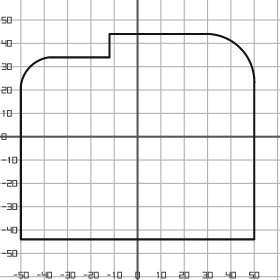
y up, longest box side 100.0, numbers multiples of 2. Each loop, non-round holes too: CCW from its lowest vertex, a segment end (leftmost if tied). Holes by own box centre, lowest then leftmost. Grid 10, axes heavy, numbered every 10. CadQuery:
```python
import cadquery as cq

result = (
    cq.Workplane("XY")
    .moveTo(-50.0, -44.0)
    .lineTo(50.0, -44.0)
    .lineTo(50.0, 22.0)
    .threePointArc((44.0, 38.0), (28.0, 44.0))
    .lineTo(-12.0, 44.0)
    .lineTo(-12.0, 34.0)
    .lineTo(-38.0, 34.0)
    .threePointArc((-46.0, 30.0), (-50.0, 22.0))
    .close()
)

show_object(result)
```